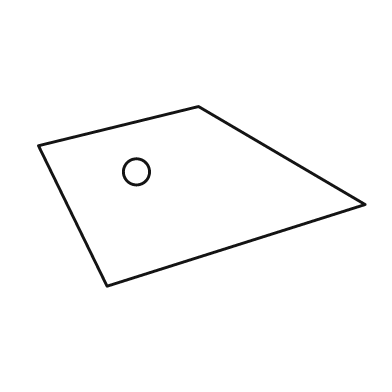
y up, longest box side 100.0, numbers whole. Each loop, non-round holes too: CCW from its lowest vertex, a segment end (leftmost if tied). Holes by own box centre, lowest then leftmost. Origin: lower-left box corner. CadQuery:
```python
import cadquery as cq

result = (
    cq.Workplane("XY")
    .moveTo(21.0, 0.0)
    .lineTo(100.0, 25.0)
    .lineTo(49.0, 55.0)
    .lineTo(0.0, 43.0)
    .close()
    .moveTo(30.0, 35.0)
    .circle(4.0)
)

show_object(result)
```